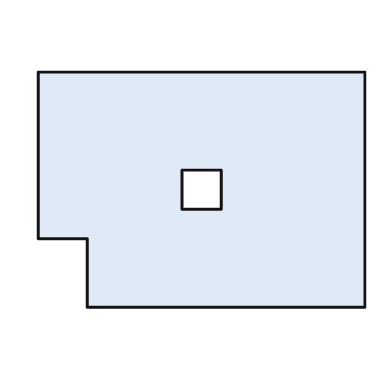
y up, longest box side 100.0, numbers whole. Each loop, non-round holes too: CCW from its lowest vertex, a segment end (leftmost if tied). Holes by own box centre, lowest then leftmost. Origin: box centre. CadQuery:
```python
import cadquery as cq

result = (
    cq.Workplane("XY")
    .moveTo(-35.0, -36.0)
    .lineTo(50.0, -36.0)
    .lineTo(50.0, 36.0)
    .lineTo(-50.0, 36.0)
    .lineTo(-50.0, -15.0)
    .lineTo(-35.0, -15.0)
    .close()
    .moveTo(-6.0, -6.0)
    .lineTo(6.0, -6.0)
    .lineTo(6.0, 6.0)
    .lineTo(-6.0, 6.0)
    .close()
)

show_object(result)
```